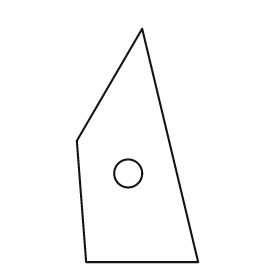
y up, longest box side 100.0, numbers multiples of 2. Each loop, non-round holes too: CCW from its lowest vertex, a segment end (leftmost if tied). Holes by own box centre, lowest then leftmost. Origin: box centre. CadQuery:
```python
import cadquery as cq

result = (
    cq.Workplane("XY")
    .moveTo(-22.0, -50.0)
    .lineTo(26.0, -50.0)
    .lineTo(2.0, 50.0)
    .lineTo(-26.0, 2.0)
    .close()
    .moveTo(-4.0, -12.0)
    .circle(6.0)
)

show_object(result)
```